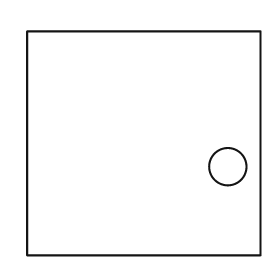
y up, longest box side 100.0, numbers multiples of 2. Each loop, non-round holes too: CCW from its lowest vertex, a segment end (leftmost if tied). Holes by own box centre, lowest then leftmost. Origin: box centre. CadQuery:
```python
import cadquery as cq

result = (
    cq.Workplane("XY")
    .moveTo(-50.0, -48.0)
    .lineTo(50.0, -48.0)
    .lineTo(50.0, 48.0)
    .lineTo(-50.0, 48.0)
    .close()
    .moveTo(36.0, -10.0)
    .circle(8.0)
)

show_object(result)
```